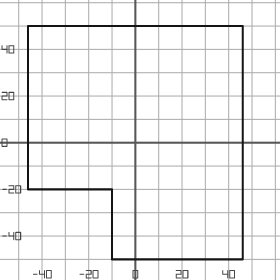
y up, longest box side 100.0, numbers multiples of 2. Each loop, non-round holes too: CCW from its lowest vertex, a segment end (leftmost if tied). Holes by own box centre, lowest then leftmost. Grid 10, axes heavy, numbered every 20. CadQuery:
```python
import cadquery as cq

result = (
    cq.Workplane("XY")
    .moveTo(-10.0, -50.0)
    .lineTo(46.0, -50.0)
    .lineTo(46.0, 50.0)
    .lineTo(-46.0, 50.0)
    .lineTo(-46.0, -20.0)
    .lineTo(-10.0, -20.0)
    .close()
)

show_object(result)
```